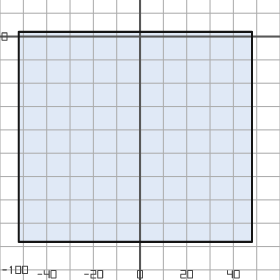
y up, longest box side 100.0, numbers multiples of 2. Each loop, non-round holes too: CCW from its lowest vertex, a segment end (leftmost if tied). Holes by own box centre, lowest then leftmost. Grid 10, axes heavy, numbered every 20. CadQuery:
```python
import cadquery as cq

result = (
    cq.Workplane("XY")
    .moveTo(-52.0, -88.0)
    .lineTo(48.0, -88.0)
    .lineTo(48.0, 2.0)
    .lineTo(-52.0, 2.0)
    .close()
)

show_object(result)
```